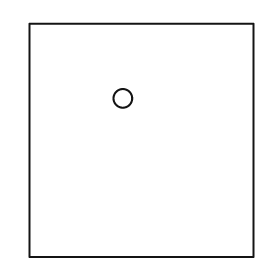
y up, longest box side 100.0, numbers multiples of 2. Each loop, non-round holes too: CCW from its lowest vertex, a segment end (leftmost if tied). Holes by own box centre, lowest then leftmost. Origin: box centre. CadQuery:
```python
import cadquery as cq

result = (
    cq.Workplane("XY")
    .moveTo(-48.0, -50.0)
    .lineTo(48.0, -50.0)
    .lineTo(48.0, 50.0)
    .lineTo(-48.0, 50.0)
    .close()
    .moveTo(-8.0, 18.0)
    .circle(4.0)
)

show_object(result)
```